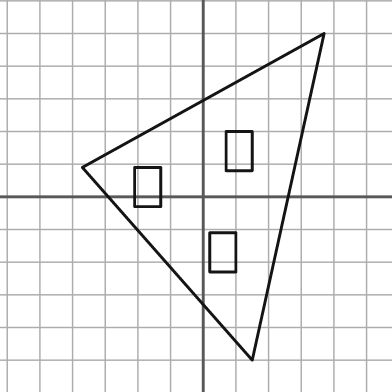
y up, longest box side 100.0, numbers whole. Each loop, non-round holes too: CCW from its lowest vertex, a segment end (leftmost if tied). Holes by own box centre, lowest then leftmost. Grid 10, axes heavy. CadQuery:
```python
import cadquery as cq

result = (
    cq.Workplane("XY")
    .moveTo(15.0, -50.0)
    .lineTo(37.0, 50.0)
    .lineTo(-37.0, 9.0)
    .close()
    .moveTo(2.0, -23.0)
    .lineTo(10.0, -23.0)
    .lineTo(10.0, -11.0)
    .lineTo(2.0, -11.0)
    .close()
    .moveTo(-21.0, -3.0)
    .lineTo(-13.0, -3.0)
    .lineTo(-13.0, 9.0)
    .lineTo(-21.0, 9.0)
    .close()
    .moveTo(7.0, 8.0)
    .lineTo(15.0, 8.0)
    .lineTo(15.0, 20.0)
    .lineTo(7.0, 20.0)
    .close()
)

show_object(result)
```